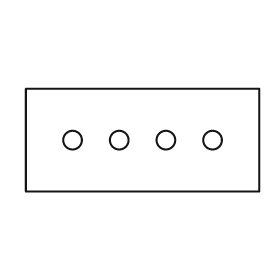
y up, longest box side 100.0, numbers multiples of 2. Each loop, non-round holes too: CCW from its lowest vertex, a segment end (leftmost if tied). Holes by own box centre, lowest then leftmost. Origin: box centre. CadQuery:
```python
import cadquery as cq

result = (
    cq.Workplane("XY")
    .moveTo(-50.0, -22.0)
    .lineTo(50.0, -22.0)
    .lineTo(50.0, 22.0)
    .lineTo(-50.0, 22.0)
    .close()
    .moveTo(-30.0, 0.0)
    .circle(4.0)
    .moveTo(-10.0, 0.0)
    .circle(4.0)
    .moveTo(10.0, 0.0)
    .circle(4.0)
    .moveTo(30.0, 0.0)
    .circle(4.0)
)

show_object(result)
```